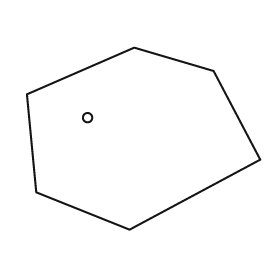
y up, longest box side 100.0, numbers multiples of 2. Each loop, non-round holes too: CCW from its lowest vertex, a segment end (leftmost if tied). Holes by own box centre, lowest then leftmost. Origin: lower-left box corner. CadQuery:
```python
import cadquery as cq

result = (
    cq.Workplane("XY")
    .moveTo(44.0, 0.0)
    .lineTo(100.0, 30.0)
    .lineTo(80.0, 68.0)
    .lineTo(46.0, 78.0)
    .lineTo(0.0, 58.0)
    .lineTo(4.0, 16.0)
    .close()
    .moveTo(26.0, 48.0)
    .circle(2.0)
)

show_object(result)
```